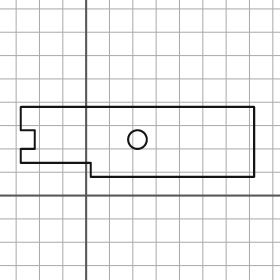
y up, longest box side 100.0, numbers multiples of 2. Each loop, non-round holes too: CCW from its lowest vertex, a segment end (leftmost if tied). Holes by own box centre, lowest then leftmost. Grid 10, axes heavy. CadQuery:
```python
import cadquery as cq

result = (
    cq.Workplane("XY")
    .moveTo(2.0, 8.0)
    .lineTo(72.0, 8.0)
    .lineTo(72.0, 38.0)
    .lineTo(-28.0, 38.0)
    .lineTo(-28.0, 28.0)
    .lineTo(-22.0, 28.0)
    .lineTo(-22.0, 20.0)
    .lineTo(-28.0, 20.0)
    .lineTo(-28.0, 14.0)
    .lineTo(2.0, 14.0)
    .close()
    .moveTo(22.0, 24.0)
    .circle(4.0)
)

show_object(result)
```